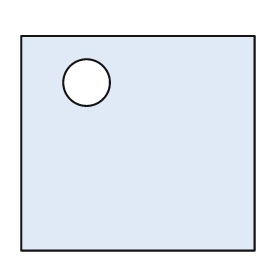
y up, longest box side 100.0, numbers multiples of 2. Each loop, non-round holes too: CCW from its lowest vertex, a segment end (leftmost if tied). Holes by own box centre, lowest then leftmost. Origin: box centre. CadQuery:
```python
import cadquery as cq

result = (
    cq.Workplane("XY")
    .moveTo(-50.0, -46.0)
    .lineTo(50.0, -46.0)
    .lineTo(50.0, 46.0)
    .lineTo(-50.0, 46.0)
    .close()
    .moveTo(-22.0, 26.0)
    .circle(10.0)
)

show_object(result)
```